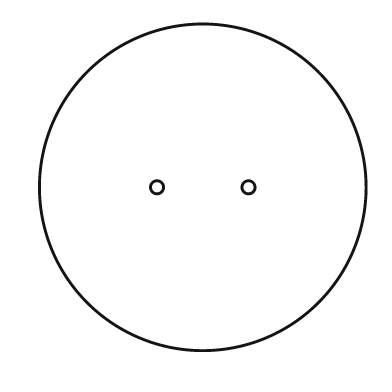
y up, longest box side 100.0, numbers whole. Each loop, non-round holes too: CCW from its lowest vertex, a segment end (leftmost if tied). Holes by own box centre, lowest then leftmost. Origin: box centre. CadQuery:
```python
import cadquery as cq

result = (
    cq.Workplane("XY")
    .moveTo(0.0, 0.0)
    .circle(50.0)
    .moveTo(-14.0, 0.0)
    .circle(2.0)
    .moveTo(14.0, 0.0)
    .circle(2.0)
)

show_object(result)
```